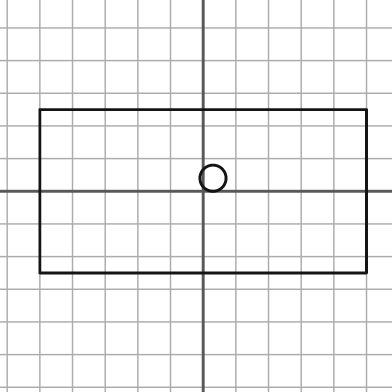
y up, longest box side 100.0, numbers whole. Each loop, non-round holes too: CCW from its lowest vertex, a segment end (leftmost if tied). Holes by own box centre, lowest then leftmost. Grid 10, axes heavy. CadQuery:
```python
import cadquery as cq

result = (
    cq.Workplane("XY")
    .moveTo(-50.0, -25.0)
    .lineTo(50.0, -25.0)
    .lineTo(50.0, 25.0)
    .lineTo(-50.0, 25.0)
    .close()
    .moveTo(3.0, 4.0)
    .circle(4.0)
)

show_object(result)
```